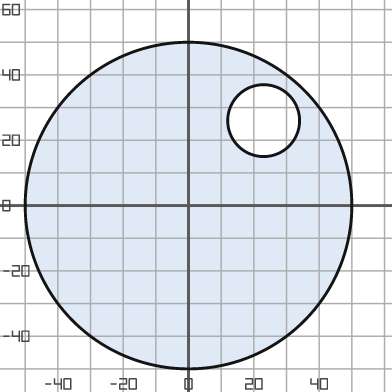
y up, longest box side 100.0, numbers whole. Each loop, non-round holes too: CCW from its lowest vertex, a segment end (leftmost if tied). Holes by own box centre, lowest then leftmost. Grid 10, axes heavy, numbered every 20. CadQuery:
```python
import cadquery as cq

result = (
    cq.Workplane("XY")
    .moveTo(0.0, 0.0)
    .circle(50.0)
    .moveTo(23.0, 26.0)
    .circle(11.0)
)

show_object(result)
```